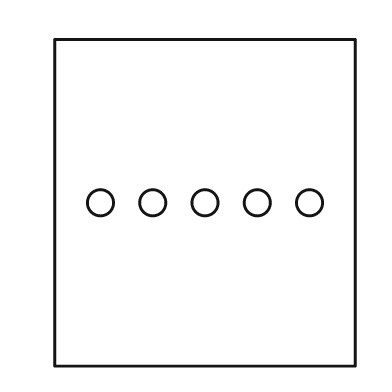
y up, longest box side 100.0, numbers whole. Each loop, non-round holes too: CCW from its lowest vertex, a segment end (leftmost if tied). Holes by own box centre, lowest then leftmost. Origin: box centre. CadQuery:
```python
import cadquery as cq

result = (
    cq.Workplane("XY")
    .moveTo(-46.0, -50.0)
    .lineTo(46.0, -50.0)
    .lineTo(46.0, 50.0)
    .lineTo(-46.0, 50.0)
    .close()
    .moveTo(-32.0, 0.0)
    .circle(4.0)
    .moveTo(-16.0, 0.0)
    .circle(4.0)
    .moveTo(0.0, 0.0)
    .circle(4.0)
    .moveTo(16.0, 0.0)
    .circle(4.0)
    .moveTo(32.0, 0.0)
    .circle(4.0)
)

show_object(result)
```